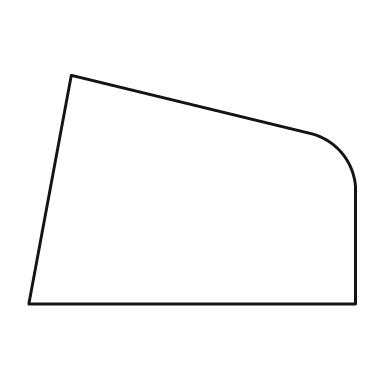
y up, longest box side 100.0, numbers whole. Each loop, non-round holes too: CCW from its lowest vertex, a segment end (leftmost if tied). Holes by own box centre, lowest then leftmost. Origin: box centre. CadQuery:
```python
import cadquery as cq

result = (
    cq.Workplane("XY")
    .moveTo(-50.0, -35.0)
    .lineTo(50.0, -35.0)
    .lineTo(50.0, 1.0)
    .threePointArc((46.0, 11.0), (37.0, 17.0))
    .lineTo(-37.0, 35.0)
    .close()
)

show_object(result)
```